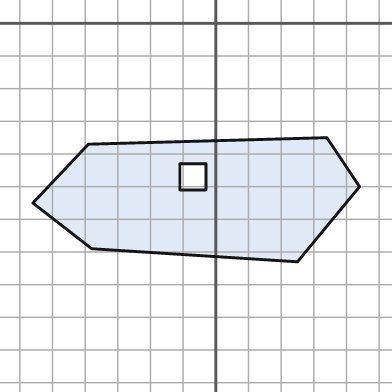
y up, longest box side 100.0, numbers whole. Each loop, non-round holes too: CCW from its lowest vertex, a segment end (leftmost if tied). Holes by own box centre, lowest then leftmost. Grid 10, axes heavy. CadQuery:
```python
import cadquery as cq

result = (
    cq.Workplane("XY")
    .moveTo(25.0, -73.0)
    .lineTo(44.0, -50.0)
    .lineTo(34.0, -35.0)
    .lineTo(-39.0, -37.0)
    .lineTo(-56.0, -55.0)
    .lineTo(-38.0, -69.0)
    .close()
    .moveTo(-11.0, -51.0)
    .lineTo(-3.0, -51.0)
    .lineTo(-3.0, -43.0)
    .lineTo(-11.0, -43.0)
    .close()
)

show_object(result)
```